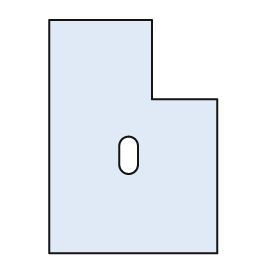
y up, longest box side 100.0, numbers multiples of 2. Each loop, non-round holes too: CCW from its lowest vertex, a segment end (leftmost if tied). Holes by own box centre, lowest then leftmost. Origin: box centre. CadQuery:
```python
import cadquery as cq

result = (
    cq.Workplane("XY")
    .moveTo(-36.0, -50.0)
    .lineTo(36.0, -50.0)
    .lineTo(36.0, 16.0)
    .lineTo(8.0, 16.0)
    .lineTo(8.0, 50.0)
    .lineTo(-36.0, 50.0)
    .close()
    .moveTo(-6.0, -12.0)
    .threePointArc((-2.0, -16.0), (2.0, -12.0))
    .lineTo(2.0, -4.0)
    .threePointArc((-2.0, 0.0), (-6.0, -4.0))
    .close()
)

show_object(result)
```